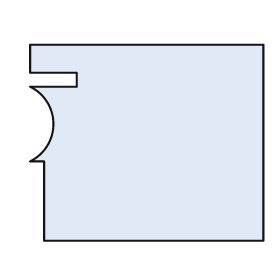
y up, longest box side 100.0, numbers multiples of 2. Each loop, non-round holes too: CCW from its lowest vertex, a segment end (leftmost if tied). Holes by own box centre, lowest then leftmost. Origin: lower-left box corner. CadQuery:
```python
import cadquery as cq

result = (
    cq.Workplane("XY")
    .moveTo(6.0, 0.0)
    .lineTo(100.0, 0.0)
    .lineTo(100.0, 84.0)
    .lineTo(0.0, 84.0)
    .lineTo(0.0, 72.0)
    .lineTo(20.0, 72.0)
    .lineTo(20.0, 66.0)
    .lineTo(0.0, 66.0)
    .threePointArc((10.0, 50.0), (0.0, 34.0))
    .lineTo(6.0, 34.0)
    .close()
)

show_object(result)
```